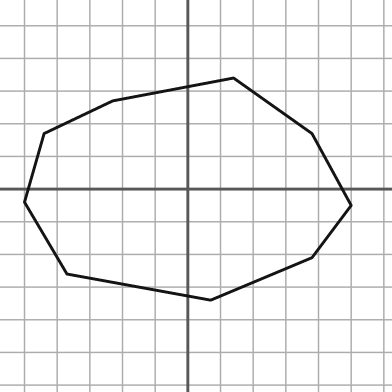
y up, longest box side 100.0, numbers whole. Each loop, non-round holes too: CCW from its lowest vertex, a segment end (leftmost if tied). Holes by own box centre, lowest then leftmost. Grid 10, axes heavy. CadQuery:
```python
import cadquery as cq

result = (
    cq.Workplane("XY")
    .moveTo(7.0, -34.0)
    .lineTo(38.0, -21.0)
    .lineTo(50.0, -5.0)
    .lineTo(38.0, 17.0)
    .lineTo(14.0, 34.0)
    .lineTo(-23.0, 27.0)
    .lineTo(-44.0, 17.0)
    .lineTo(-50.0, -4.0)
    .lineTo(-37.0, -26.0)
    .close()
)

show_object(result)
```